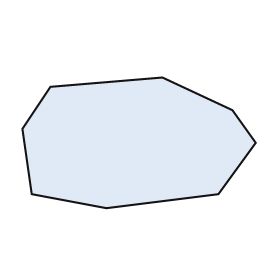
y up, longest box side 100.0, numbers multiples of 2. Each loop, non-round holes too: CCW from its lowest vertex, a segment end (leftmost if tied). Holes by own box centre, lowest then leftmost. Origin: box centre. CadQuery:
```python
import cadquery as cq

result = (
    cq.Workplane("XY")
    .moveTo(-14.0, -28.0)
    .lineTo(34.0, -22.0)
    .lineTo(50.0, 0.0)
    .lineTo(40.0, 14.0)
    .lineTo(10.0, 28.0)
    .lineTo(-38.0, 24.0)
    .lineTo(-50.0, 6.0)
    .lineTo(-46.0, -22.0)
    .close()
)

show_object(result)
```